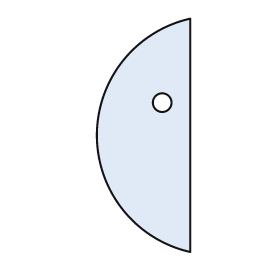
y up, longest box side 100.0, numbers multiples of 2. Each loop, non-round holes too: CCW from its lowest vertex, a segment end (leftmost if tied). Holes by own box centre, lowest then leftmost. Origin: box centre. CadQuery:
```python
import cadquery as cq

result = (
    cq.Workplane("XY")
    .moveTo(20.0, -50.0)
    .lineTo(20.0, 50.0)
    .threePointArc((-20.0, 0.0), (20.0, -50.0))
    .close()
    .moveTo(8.0, 14.0)
    .circle(4.0)
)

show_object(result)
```